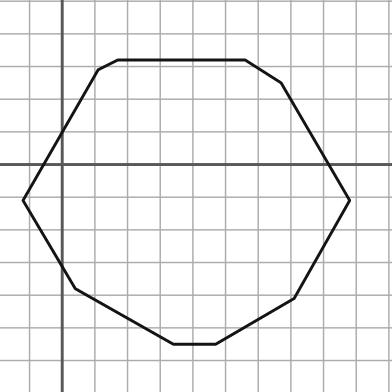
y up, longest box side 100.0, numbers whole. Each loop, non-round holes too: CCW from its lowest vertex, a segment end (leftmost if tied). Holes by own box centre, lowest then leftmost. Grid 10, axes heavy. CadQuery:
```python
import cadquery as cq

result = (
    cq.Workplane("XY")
    .moveTo(34.0, -55.0)
    .lineTo(47.0, -55.0)
    .lineTo(71.0, -41.0)
    .lineTo(88.0, -11.0)
    .lineTo(67.0, 25.0)
    .lineTo(56.0, 32.0)
    .lineTo(17.0, 32.0)
    .lineTo(11.0, 29.0)
    .lineTo(-12.0, -11.0)
    .lineTo(4.0, -38.0)
    .close()
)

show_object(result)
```